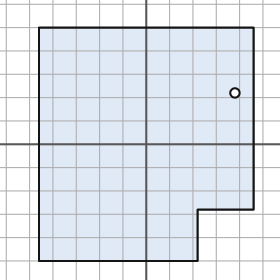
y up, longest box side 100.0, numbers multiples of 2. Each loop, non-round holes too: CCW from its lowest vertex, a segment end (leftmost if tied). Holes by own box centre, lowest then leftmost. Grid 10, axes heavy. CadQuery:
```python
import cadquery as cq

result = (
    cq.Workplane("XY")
    .moveTo(-46.0, -50.0)
    .lineTo(22.0, -50.0)
    .lineTo(22.0, -28.0)
    .lineTo(46.0, -28.0)
    .lineTo(46.0, 50.0)
    .lineTo(-46.0, 50.0)
    .close()
    .moveTo(38.0, 22.0)
    .circle(2.0)
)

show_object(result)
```